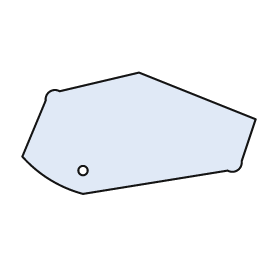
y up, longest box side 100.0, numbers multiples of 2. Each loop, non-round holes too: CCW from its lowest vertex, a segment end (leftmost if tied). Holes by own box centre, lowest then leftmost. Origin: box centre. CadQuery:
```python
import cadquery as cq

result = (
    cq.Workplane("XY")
    .moveTo(-24.0, -26.0)
    .lineTo(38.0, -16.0)
    .threePointArc((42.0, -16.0), (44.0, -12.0))
    .lineTo(50.0, 6.0)
    .lineTo(0.0, 26.0)
    .lineTo(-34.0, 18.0)
    .threePointArc((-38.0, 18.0), (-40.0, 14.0))
    .lineTo(-50.0, -10.0)
    .threePointArc((-38.0, -20.0), (-24.0, -26.0))
    .close()
    .moveTo(-24.0, -16.0)
    .circle(2.0)
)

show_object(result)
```